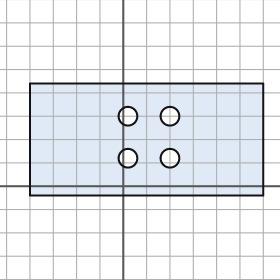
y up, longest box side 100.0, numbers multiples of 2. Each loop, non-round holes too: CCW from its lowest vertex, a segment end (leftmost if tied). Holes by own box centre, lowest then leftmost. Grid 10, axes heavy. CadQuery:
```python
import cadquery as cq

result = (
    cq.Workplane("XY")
    .moveTo(-40.0, -4.0)
    .lineTo(60.0, -4.0)
    .lineTo(60.0, 44.0)
    .lineTo(-40.0, 44.0)
    .close()
    .moveTo(2.0, 12.0)
    .circle(4.0)
    .moveTo(20.0, 12.0)
    .circle(4.0)
    .moveTo(2.0, 30.0)
    .circle(4.0)
    .moveTo(20.0, 30.0)
    .circle(4.0)
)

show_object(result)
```